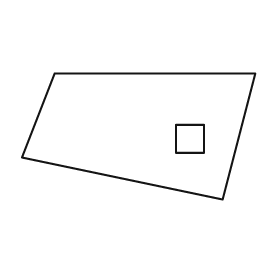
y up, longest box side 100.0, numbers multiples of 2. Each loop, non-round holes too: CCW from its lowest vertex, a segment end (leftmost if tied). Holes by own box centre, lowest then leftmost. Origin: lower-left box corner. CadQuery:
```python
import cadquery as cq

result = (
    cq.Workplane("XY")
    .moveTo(86.0, 0.0)
    .lineTo(100.0, 54.0)
    .lineTo(14.0, 54.0)
    .lineTo(0.0, 18.0)
    .close()
    .moveTo(66.0, 20.0)
    .lineTo(78.0, 20.0)
    .lineTo(78.0, 32.0)
    .lineTo(66.0, 32.0)
    .close()
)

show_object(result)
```